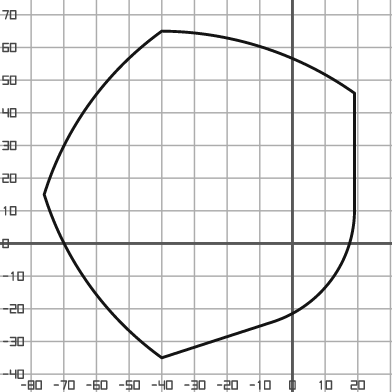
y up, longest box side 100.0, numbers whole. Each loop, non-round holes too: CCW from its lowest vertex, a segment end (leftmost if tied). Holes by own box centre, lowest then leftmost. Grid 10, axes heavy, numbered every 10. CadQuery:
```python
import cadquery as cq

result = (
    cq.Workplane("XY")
    .moveTo(-40.0, -35.0)
    .lineTo(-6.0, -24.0)
    .threePointArc((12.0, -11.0), (19.0, 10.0))
    .lineTo(19.0, 46.0)
    .threePointArc((-9.0, 60.0), (-40.0, 65.0))
    .threePointArc((-62.0, 43.0), (-76.0, 15.0))
    .threePointArc((-62.0, -13.0), (-40.0, -35.0))
    .close()
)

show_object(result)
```